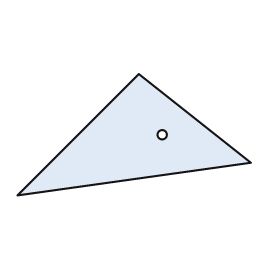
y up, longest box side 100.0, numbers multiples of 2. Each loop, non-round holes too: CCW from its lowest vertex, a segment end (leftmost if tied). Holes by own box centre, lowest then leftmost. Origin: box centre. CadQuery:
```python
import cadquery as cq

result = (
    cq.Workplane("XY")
    .moveTo(-50.0, -26.0)
    .lineTo(50.0, -12.0)
    .lineTo(2.0, 26.0)
    .close()
    .moveTo(12.0, 0.0)
    .circle(2.0)
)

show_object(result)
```